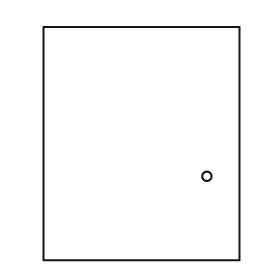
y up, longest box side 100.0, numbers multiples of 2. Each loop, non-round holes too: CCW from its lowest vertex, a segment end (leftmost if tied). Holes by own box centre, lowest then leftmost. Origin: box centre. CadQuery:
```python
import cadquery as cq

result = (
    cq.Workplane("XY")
    .moveTo(-42.0, -50.0)
    .lineTo(42.0, -50.0)
    .lineTo(42.0, 50.0)
    .lineTo(-42.0, 50.0)
    .close()
    .moveTo(28.0, -14.0)
    .circle(2.0)
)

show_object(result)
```